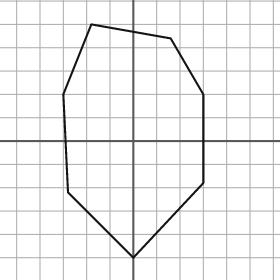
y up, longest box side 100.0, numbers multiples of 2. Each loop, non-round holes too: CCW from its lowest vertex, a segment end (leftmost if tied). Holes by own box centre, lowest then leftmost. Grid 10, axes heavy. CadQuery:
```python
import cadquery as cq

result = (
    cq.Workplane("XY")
    .moveTo(0.0, -50.0)
    .lineTo(30.0, -18.0)
    .lineTo(30.0, 20.0)
    .lineTo(16.0, 44.0)
    .lineTo(-18.0, 50.0)
    .lineTo(-30.0, 20.0)
    .lineTo(-28.0, -22.0)
    .close()
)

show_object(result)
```